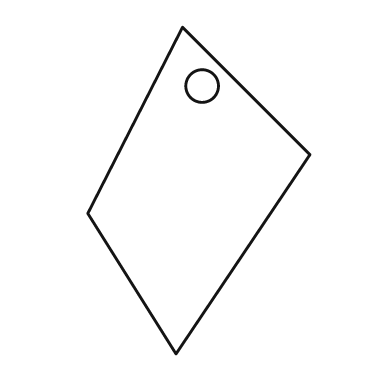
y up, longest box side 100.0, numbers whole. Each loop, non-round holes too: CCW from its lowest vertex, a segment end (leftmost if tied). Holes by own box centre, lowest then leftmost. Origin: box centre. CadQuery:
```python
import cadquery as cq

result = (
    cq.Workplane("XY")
    .moveTo(-7.0, -50.0)
    .lineTo(34.0, 11.0)
    .lineTo(-5.0, 50.0)
    .lineTo(-34.0, -7.0)
    .close()
    .moveTo(1.0, 32.0)
    .circle(5.0)
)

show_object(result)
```